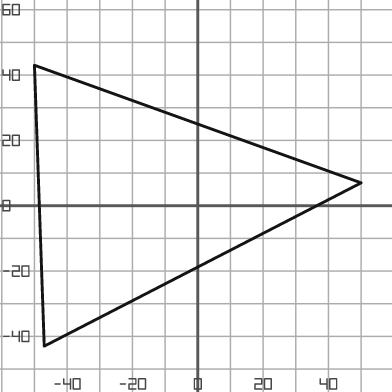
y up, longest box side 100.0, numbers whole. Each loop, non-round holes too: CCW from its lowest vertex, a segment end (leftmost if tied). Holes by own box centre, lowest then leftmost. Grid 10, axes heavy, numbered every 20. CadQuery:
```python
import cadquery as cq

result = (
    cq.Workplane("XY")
    .moveTo(-47.0, -43.0)
    .lineTo(50.0, 7.0)
    .lineTo(-50.0, 43.0)
    .close()
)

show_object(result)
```